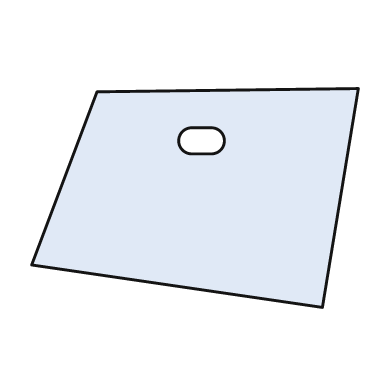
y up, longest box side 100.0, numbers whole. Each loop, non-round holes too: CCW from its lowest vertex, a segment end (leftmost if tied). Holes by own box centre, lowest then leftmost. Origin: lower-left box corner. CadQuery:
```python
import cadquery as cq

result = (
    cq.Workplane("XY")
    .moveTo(89.0, 0.0)
    .lineTo(100.0, 67.0)
    .lineTo(20.0, 66.0)
    .lineTo(0.0, 13.0)
    .close()
    .moveTo(49.0, 47.0)
    .lineTo(55.0, 47.0)
    .threePointArc((59.0, 51.0), (55.0, 55.0))
    .lineTo(49.0, 55.0)
    .threePointArc((45.0, 51.0), (49.0, 47.0))
    .close()
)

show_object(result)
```